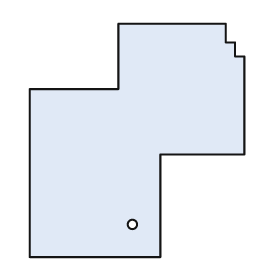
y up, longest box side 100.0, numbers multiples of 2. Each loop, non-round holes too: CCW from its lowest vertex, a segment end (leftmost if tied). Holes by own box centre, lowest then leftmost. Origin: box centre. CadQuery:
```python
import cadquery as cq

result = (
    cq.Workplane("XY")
    .moveTo(-46.0, -50.0)
    .lineTo(10.0, -50.0)
    .lineTo(10.0, -6.0)
    .lineTo(46.0, -6.0)
    .lineTo(46.0, 36.0)
    .lineTo(42.0, 36.0)
    .lineTo(42.0, 42.0)
    .lineTo(38.0, 42.0)
    .lineTo(38.0, 50.0)
    .lineTo(-8.0, 50.0)
    .lineTo(-8.0, 22.0)
    .lineTo(-46.0, 22.0)
    .close()
    .moveTo(-2.0, -36.0)
    .circle(2.0)
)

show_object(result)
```